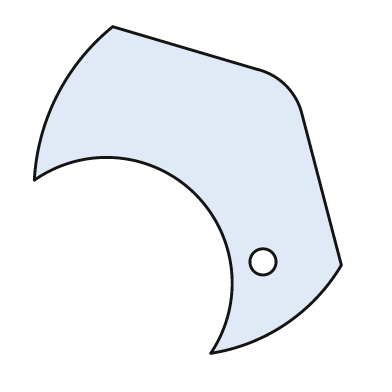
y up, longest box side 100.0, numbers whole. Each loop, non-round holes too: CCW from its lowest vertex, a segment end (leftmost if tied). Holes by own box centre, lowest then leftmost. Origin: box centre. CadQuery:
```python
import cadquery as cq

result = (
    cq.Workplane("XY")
    .moveTo(7.0, -50.0)
    .threePointArc((30.0, -41.0), (47.0, -23.0))
    .lineTo(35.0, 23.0)
    .threePointArc((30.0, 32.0), (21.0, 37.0))
    .lineTo(-23.0, 50.0)
    .threePointArc((-40.0, 29.0), (-47.0, 3.0))
    .threePointArc((2.0, -1.0), (7.0, -50.0))
    .close()
    .moveTo(23.0, -22.0)
    .circle(4.0)
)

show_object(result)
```